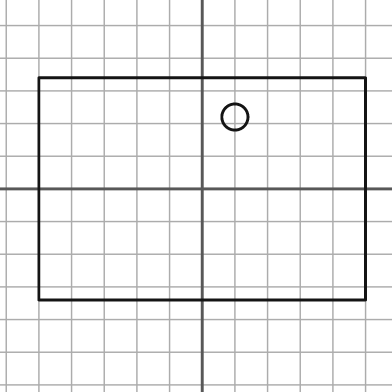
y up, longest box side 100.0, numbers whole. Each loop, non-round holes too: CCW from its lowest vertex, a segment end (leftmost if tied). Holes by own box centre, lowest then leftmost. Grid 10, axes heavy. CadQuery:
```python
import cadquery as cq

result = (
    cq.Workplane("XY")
    .moveTo(-50.0, -34.0)
    .lineTo(50.0, -34.0)
    .lineTo(50.0, 34.0)
    .lineTo(-50.0, 34.0)
    .close()
    .moveTo(10.0, 22.0)
    .circle(4.0)
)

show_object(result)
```